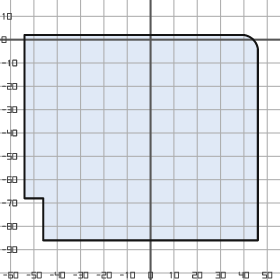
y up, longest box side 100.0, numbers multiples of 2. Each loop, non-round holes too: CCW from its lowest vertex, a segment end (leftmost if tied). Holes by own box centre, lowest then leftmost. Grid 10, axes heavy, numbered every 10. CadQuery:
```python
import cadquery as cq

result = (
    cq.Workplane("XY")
    .moveTo(-46.0, -86.0)
    .lineTo(46.0, -86.0)
    .lineTo(46.0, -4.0)
    .threePointArc((44.0, 0.0), (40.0, 2.0))
    .lineTo(-54.0, 2.0)
    .lineTo(-54.0, -68.0)
    .lineTo(-46.0, -68.0)
    .close()
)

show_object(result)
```